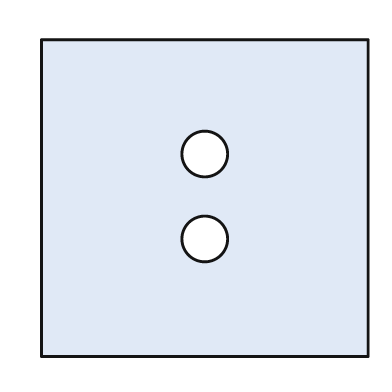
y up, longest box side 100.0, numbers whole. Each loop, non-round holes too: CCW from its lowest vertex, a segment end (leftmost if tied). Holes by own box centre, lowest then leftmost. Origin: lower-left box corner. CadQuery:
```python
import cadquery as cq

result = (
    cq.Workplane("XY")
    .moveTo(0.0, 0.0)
    .lineTo(100.0, 0.0)
    .lineTo(100.0, 97.0)
    .lineTo(0.0, 97.0)
    .close()
    .moveTo(50.0, 36.0)
    .circle(7.0)
    .moveTo(50.0, 62.0)
    .circle(7.0)
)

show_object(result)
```